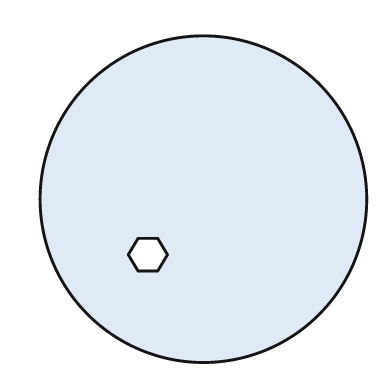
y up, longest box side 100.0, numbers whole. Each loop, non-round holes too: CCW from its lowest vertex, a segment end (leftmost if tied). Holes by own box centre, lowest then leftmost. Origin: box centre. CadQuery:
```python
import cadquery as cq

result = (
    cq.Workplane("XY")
    .moveTo(0.0, 0.0)
    .circle(50.0)
    .moveTo(-20.0, -22.0)
    .lineTo(-14.0, -22.0)
    .lineTo(-11.0, -17.0)
    .lineTo(-14.0, -12.0)
    .lineTo(-20.0, -12.0)
    .lineTo(-23.0, -17.0)
    .close()
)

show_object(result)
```